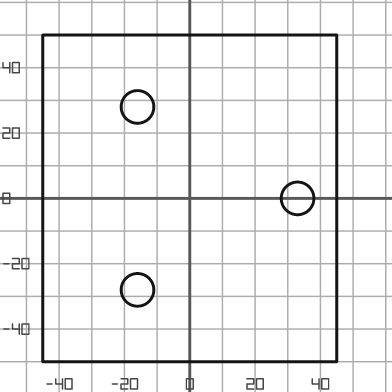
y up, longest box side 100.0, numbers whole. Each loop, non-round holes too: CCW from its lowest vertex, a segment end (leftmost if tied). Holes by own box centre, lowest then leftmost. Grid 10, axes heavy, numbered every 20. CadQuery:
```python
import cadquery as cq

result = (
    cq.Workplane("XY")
    .moveTo(-45.0, -50.0)
    .lineTo(45.0, -50.0)
    .lineTo(45.0, 50.0)
    .lineTo(-45.0, 50.0)
    .close()
    .moveTo(-16.0, -28.0)
    .circle(5.0)
    .moveTo(33.0, 0.0)
    .circle(5.0)
    .moveTo(-16.0, 28.0)
    .circle(5.0)
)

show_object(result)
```